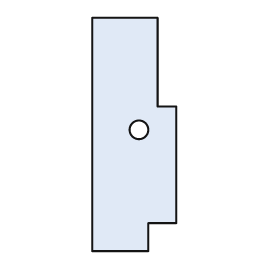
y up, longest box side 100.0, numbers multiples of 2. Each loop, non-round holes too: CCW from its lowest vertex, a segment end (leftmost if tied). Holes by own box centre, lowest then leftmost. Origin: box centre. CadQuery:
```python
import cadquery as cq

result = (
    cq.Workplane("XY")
    .moveTo(-18.0, -50.0)
    .lineTo(6.0, -50.0)
    .lineTo(6.0, -38.0)
    .lineTo(18.0, -38.0)
    .lineTo(18.0, 12.0)
    .lineTo(10.0, 12.0)
    .lineTo(10.0, 50.0)
    .lineTo(-18.0, 50.0)
    .close()
    .moveTo(2.0, 2.0)
    .circle(4.0)
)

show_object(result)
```